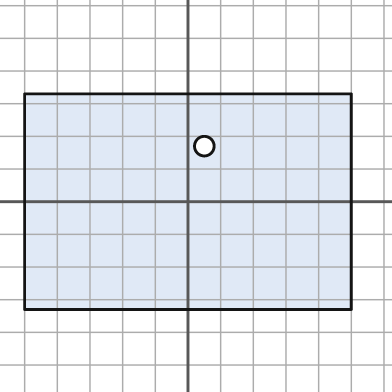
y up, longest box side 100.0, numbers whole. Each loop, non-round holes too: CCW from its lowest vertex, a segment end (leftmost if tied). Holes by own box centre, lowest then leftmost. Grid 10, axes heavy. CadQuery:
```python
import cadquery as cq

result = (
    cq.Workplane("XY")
    .moveTo(-50.0, -33.0)
    .lineTo(50.0, -33.0)
    .lineTo(50.0, 33.0)
    .lineTo(-50.0, 33.0)
    .close()
    .moveTo(5.0, 17.0)
    .circle(3.0)
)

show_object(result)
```